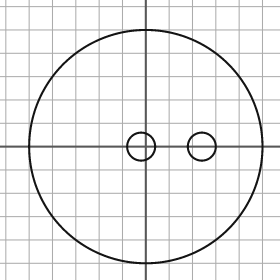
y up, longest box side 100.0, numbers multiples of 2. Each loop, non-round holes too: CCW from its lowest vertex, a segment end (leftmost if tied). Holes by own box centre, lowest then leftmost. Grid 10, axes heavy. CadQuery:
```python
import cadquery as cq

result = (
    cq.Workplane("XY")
    .moveTo(0.0, 0.0)
    .circle(50.0)
    .moveTo(-2.0, 0.0)
    .circle(6.0)
    .moveTo(24.0, 0.0)
    .circle(6.0)
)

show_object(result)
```